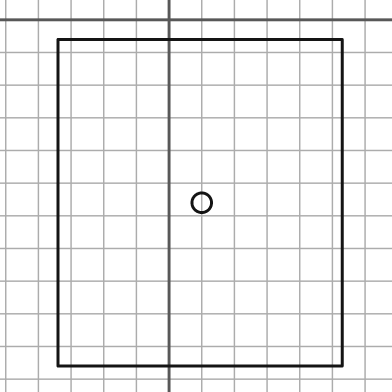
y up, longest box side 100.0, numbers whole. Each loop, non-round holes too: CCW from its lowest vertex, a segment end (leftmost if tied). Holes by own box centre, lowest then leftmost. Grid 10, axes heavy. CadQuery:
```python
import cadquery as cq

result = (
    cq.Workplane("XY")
    .moveTo(-34.0, -106.0)
    .lineTo(53.0, -106.0)
    .lineTo(53.0, -6.0)
    .lineTo(-34.0, -6.0)
    .close()
    .moveTo(10.0, -56.0)
    .circle(3.0)
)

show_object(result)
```